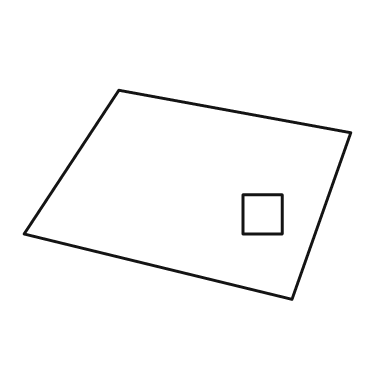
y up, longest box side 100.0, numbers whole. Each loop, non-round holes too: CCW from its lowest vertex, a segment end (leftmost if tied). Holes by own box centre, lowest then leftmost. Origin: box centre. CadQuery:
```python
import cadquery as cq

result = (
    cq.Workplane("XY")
    .moveTo(32.0, -32.0)
    .lineTo(50.0, 19.0)
    .lineTo(-21.0, 32.0)
    .lineTo(-50.0, -12.0)
    .close()
    .moveTo(17.0, -12.0)
    .lineTo(29.0, -12.0)
    .lineTo(29.0, 0.0)
    .lineTo(17.0, 0.0)
    .close()
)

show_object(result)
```